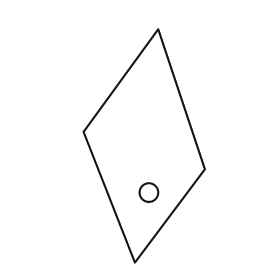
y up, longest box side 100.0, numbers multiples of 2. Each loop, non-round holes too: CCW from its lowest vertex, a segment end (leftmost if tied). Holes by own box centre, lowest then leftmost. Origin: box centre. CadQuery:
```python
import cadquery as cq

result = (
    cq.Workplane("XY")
    .moveTo(-4.0, -50.0)
    .lineTo(26.0, -10.0)
    .lineTo(6.0, 50.0)
    .lineTo(-26.0, 6.0)
    .close()
    .moveTo(2.0, -20.0)
    .circle(4.0)
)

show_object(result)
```